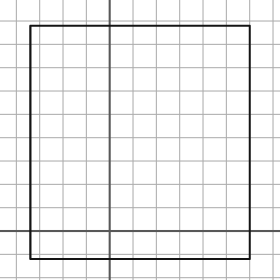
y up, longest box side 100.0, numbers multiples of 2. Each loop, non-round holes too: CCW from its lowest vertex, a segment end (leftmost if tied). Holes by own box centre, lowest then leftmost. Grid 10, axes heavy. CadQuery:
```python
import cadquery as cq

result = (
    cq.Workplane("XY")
    .moveTo(-34.0, -12.0)
    .lineTo(60.0, -12.0)
    .lineTo(60.0, 88.0)
    .lineTo(-34.0, 88.0)
    .close()
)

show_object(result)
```